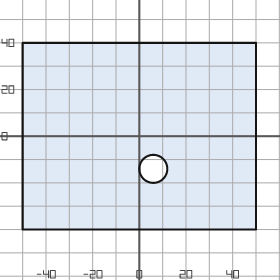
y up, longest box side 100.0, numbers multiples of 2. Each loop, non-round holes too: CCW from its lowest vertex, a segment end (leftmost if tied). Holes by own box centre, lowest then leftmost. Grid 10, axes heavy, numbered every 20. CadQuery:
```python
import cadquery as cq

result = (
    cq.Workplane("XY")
    .moveTo(-50.0, -40.0)
    .lineTo(50.0, -40.0)
    .lineTo(50.0, 40.0)
    .lineTo(-50.0, 40.0)
    .close()
    .moveTo(6.0, -14.0)
    .circle(6.0)
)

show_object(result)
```